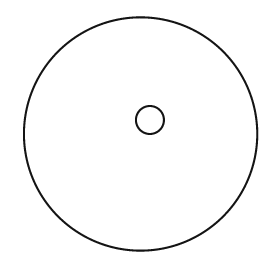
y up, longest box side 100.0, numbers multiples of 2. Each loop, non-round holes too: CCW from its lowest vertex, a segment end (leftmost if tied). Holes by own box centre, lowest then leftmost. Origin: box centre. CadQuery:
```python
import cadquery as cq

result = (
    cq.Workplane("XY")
    .moveTo(0.0, 0.0)
    .circle(50.0)
    .moveTo(4.0, 6.0)
    .circle(6.0)
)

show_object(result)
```